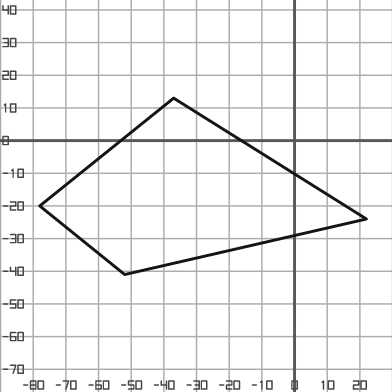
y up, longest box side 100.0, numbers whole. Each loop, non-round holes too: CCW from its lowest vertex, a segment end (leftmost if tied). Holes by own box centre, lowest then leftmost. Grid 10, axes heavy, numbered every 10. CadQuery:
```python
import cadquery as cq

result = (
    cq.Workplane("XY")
    .moveTo(-52.0, -41.0)
    .lineTo(22.0, -24.0)
    .lineTo(-37.0, 13.0)
    .lineTo(-78.0, -20.0)
    .close()
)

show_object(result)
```